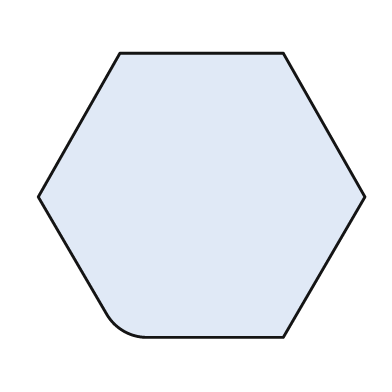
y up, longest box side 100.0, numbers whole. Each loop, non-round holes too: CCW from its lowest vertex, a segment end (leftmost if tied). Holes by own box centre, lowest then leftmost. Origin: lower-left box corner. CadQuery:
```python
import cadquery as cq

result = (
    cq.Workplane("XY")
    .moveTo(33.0, 0.0)
    .lineTo(75.0, 0.0)
    .lineTo(100.0, 43.0)
    .lineTo(75.0, 87.0)
    .lineTo(25.0, 87.0)
    .lineTo(0.0, 43.0)
    .lineTo(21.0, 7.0)
    .threePointArc((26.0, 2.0), (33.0, 0.0))
    .close()
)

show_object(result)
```